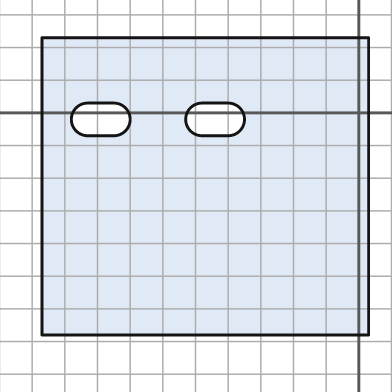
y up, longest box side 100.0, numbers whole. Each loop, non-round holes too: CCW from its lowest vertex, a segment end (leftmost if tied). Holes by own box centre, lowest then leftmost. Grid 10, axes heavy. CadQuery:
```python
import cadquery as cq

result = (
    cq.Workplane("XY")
    .moveTo(-97.0, -68.0)
    .lineTo(3.0, -68.0)
    .lineTo(3.0, 23.0)
    .lineTo(-97.0, 23.0)
    .close()
    .moveTo(-83.0, -7.0)
    .lineTo(-75.0, -7.0)
    .threePointArc((-70.0, -2.0), (-75.0, 3.0))
    .lineTo(-83.0, 3.0)
    .threePointArc((-88.0, -2.0), (-83.0, -7.0))
    .close()
    .moveTo(-48.0, -7.0)
    .lineTo(-40.0, -7.0)
    .threePointArc((-35.0, -2.0), (-40.0, 3.0))
    .lineTo(-48.0, 3.0)
    .threePointArc((-53.0, -2.0), (-48.0, -7.0))
    .close()
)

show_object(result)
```